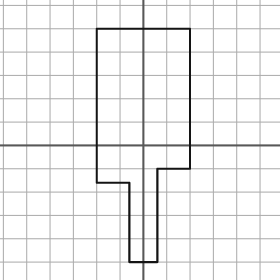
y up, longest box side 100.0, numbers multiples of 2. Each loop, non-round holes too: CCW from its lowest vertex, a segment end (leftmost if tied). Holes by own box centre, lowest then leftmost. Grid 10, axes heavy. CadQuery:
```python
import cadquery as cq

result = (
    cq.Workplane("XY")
    .moveTo(-6.0, -50.0)
    .lineTo(6.0, -50.0)
    .lineTo(6.0, -10.0)
    .lineTo(20.0, -10.0)
    .lineTo(20.0, 50.0)
    .lineTo(-20.0, 50.0)
    .lineTo(-20.0, -16.0)
    .lineTo(-6.0, -16.0)
    .close()
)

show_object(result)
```